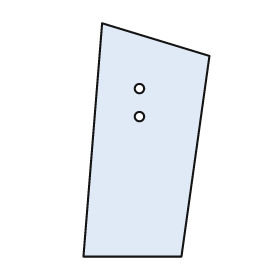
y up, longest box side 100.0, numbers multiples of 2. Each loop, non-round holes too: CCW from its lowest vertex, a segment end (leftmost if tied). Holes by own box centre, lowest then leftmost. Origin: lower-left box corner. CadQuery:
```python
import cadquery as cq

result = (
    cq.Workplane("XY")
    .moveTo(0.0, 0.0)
    .lineTo(42.0, 0.0)
    .lineTo(54.0, 86.0)
    .lineTo(8.0, 100.0)
    .close()
    .moveTo(24.0, 60.0)
    .circle(2.0)
    .moveTo(24.0, 72.0)
    .circle(2.0)
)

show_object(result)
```